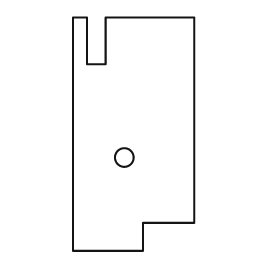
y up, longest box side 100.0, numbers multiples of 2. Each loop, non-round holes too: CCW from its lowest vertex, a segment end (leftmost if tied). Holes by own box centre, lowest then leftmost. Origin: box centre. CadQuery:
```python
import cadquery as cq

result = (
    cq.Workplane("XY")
    .moveTo(-26.0, -50.0)
    .lineTo(4.0, -50.0)
    .lineTo(4.0, -38.0)
    .lineTo(26.0, -38.0)
    .lineTo(26.0, 50.0)
    .lineTo(-12.0, 50.0)
    .lineTo(-12.0, 30.0)
    .lineTo(-20.0, 30.0)
    .lineTo(-20.0, 50.0)
    .lineTo(-26.0, 50.0)
    .close()
    .moveTo(-4.0, -10.0)
    .circle(4.0)
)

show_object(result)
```